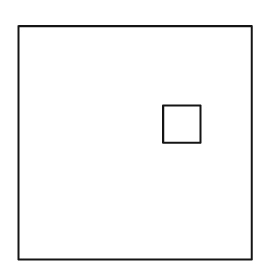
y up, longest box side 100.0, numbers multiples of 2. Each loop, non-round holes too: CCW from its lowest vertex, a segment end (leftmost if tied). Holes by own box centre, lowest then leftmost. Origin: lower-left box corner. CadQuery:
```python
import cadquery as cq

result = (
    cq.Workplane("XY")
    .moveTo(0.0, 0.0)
    .lineTo(100.0, 0.0)
    .lineTo(100.0, 100.0)
    .lineTo(0.0, 100.0)
    .close()
    .moveTo(62.0, 50.0)
    .lineTo(78.0, 50.0)
    .lineTo(78.0, 66.0)
    .lineTo(62.0, 66.0)
    .close()
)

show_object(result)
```